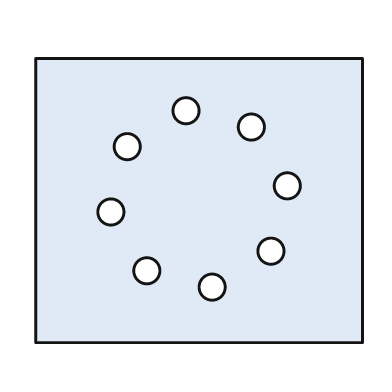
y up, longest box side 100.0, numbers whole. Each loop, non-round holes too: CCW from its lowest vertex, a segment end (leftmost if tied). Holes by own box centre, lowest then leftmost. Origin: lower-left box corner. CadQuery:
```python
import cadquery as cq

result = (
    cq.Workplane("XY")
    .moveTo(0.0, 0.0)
    .lineTo(100.0, 0.0)
    .lineTo(100.0, 87.0)
    .lineTo(0.0, 87.0)
    .close()
    .moveTo(54.0, 17.0)
    .circle(4.0)
    .moveTo(34.0, 22.0)
    .circle(4.0)
    .moveTo(72.0, 28.0)
    .circle(4.0)
    .moveTo(23.0, 40.0)
    .circle(4.0)
    .moveTo(77.0, 48.0)
    .circle(4.0)
    .moveTo(28.0, 60.0)
    .circle(4.0)
    .moveTo(66.0, 66.0)
    .circle(4.0)
    .moveTo(46.0, 71.0)
    .circle(4.0)
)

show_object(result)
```